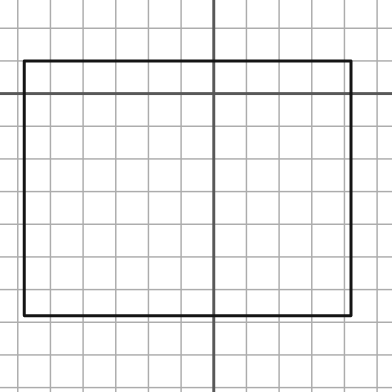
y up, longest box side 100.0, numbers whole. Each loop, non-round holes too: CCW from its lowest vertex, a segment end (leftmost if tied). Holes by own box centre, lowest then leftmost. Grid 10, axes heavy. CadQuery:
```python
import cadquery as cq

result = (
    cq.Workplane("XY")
    .moveTo(-58.0, -68.0)
    .lineTo(42.0, -68.0)
    .lineTo(42.0, 10.0)
    .lineTo(-58.0, 10.0)
    .close()
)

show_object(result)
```